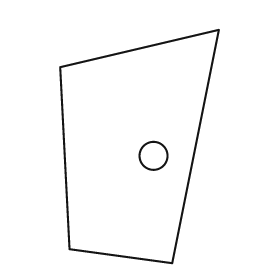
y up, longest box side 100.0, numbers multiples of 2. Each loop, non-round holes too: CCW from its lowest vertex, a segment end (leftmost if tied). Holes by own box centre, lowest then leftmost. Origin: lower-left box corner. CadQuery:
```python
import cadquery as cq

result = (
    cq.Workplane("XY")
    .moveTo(48.0, 0.0)
    .lineTo(68.0, 100.0)
    .lineTo(0.0, 84.0)
    .lineTo(4.0, 6.0)
    .close()
    .moveTo(40.0, 46.0)
    .circle(6.0)
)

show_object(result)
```